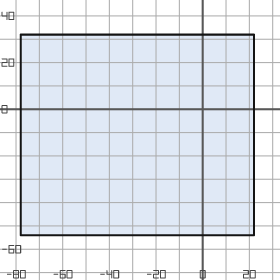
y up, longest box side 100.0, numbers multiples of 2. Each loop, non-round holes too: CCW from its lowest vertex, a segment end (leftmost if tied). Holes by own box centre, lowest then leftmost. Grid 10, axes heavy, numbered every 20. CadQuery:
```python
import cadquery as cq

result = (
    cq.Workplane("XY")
    .moveTo(-78.0, -54.0)
    .lineTo(22.0, -54.0)
    .lineTo(22.0, 32.0)
    .lineTo(-78.0, 32.0)
    .close()
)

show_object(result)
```